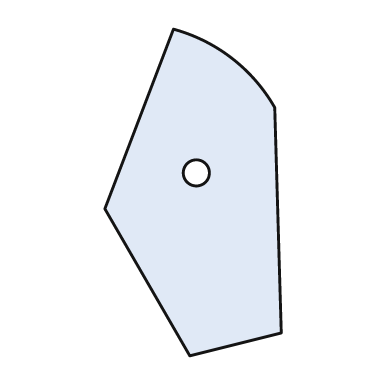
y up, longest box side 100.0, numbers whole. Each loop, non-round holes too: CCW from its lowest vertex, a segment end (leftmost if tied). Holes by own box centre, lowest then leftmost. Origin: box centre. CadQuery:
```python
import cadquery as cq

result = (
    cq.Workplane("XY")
    .moveTo(-1.0, -50.0)
    .lineTo(27.0, -43.0)
    .lineTo(25.0, 26.0)
    .threePointArc((12.0, 41.0), (-6.0, 50.0))
    .lineTo(-27.0, -5.0)
    .close()
    .moveTo(1.0, 6.0)
    .circle(4.0)
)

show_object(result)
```